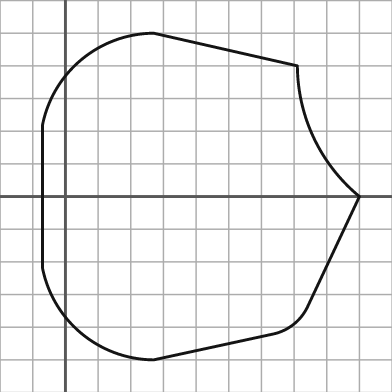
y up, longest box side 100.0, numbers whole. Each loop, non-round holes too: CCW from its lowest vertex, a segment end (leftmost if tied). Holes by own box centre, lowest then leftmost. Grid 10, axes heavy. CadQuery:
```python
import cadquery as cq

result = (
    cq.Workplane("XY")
    .moveTo(27.0, -50.0)
    .lineTo(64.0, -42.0)
    .threePointArc((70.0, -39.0), (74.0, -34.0))
    .lineTo(90.0, 0.0)
    .threePointArc((76.0, 18.0), (71.0, 40.0))
    .lineTo(27.0, 50.0)
    .threePointArc((5.0, 42.0), (-7.0, 22.0))
    .lineTo(-7.0, -22.0)
    .threePointArc((5.0, -42.0), (27.0, -50.0))
    .close()
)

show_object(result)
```